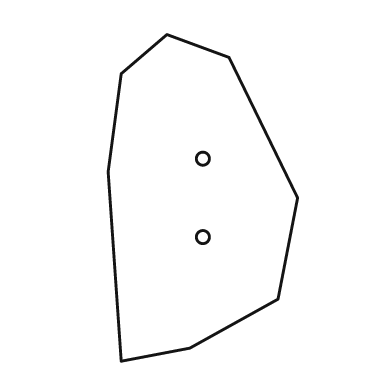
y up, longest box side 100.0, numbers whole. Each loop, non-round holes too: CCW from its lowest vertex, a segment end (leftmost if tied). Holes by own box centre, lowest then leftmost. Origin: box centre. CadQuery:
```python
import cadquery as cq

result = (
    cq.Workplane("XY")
    .moveTo(-25.0, -50.0)
    .lineTo(-4.0, -46.0)
    .lineTo(23.0, -31.0)
    .lineTo(29.0, 0.0)
    .lineTo(8.0, 43.0)
    .lineTo(-11.0, 50.0)
    .lineTo(-25.0, 38.0)
    .lineTo(-29.0, 8.0)
    .close()
    .moveTo(0.0, -12.0)
    .circle(2.0)
    .moveTo(0.0, 12.0)
    .circle(2.0)
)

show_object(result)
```